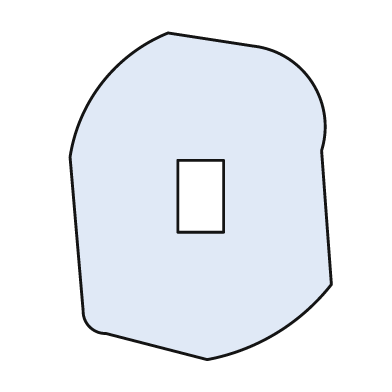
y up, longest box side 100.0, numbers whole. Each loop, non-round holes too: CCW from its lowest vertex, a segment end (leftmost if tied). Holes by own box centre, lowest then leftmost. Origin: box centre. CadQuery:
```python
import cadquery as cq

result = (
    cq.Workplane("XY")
    .moveTo(2.0, -50.0)
    .threePointArc((23.0, -42.0), (40.0, -27.0))
    .lineTo(37.0, 14.0)
    .threePointArc((34.0, 35.0), (16.0, 46.0))
    .lineTo(-10.0, 50.0)
    .threePointArc((-30.0, 35.0), (-40.0, 12.0))
    .lineTo(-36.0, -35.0)
    .threePointArc((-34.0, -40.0), (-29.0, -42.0))
    .close()
    .moveTo(-7.0, -11.0)
    .lineTo(7.0, -11.0)
    .lineTo(7.0, 11.0)
    .lineTo(-7.0, 11.0)
    .close()
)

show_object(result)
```